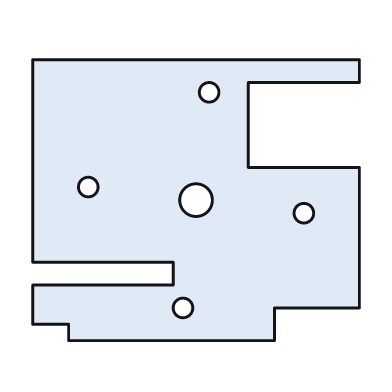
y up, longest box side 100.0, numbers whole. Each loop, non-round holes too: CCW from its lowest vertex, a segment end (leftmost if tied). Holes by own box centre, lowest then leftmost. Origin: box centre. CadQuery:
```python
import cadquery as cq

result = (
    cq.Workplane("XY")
    .moveTo(-39.0, -43.0)
    .lineTo(24.0, -43.0)
    .lineTo(24.0, -33.0)
    .lineTo(50.0, -33.0)
    .lineTo(50.0, 10.0)
    .lineTo(16.0, 10.0)
    .lineTo(16.0, 36.0)
    .lineTo(50.0, 36.0)
    .lineTo(50.0, 43.0)
    .lineTo(-50.0, 43.0)
    .lineTo(-50.0, -19.0)
    .lineTo(-7.0, -19.0)
    .lineTo(-7.0, -26.0)
    .lineTo(-50.0, -26.0)
    .lineTo(-50.0, -38.0)
    .lineTo(-39.0, -38.0)
    .close()
    .moveTo(-4.0, -33.0)
    .circle(3.0)
    .moveTo(33.0, -4.0)
    .circle(3.0)
    .moveTo(0.0, 0.0)
    .circle(5.0)
    .moveTo(-33.0, 4.0)
    .circle(3.0)
    .moveTo(4.0, 33.0)
    .circle(3.0)
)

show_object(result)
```